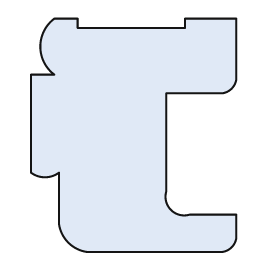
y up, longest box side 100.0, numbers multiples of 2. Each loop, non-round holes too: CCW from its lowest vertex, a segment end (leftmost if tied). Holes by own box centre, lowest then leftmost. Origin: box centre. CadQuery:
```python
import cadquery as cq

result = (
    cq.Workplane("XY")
    .moveTo(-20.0, -50.0)
    .lineTo(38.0, -50.0)
    .threePointArc((42.0, -48.0), (44.0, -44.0))
    .lineTo(44.0, -34.0)
    .lineTo(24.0, -34.0)
    .threePointArc((16.0, -32.0), (14.0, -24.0))
    .lineTo(14.0, 18.0)
    .lineTo(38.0, 18.0)
    .threePointArc((42.0, 20.0), (44.0, 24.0))
    .lineTo(44.0, 50.0)
    .lineTo(22.0, 50.0)
    .lineTo(22.0, 46.0)
    .lineTo(-24.0, 46.0)
    .lineTo(-24.0, 50.0)
    .lineTo(-34.0, 50.0)
    .threePointArc((-40.0, 38.0), (-34.0, 26.0))
    .lineTo(-44.0, 26.0)
    .lineTo(-44.0, -16.0)
    .threePointArc((-38.0, -18.0), (-32.0, -16.0))
    .lineTo(-32.0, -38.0)
    .threePointArc((-28.0, -46.0), (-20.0, -50.0))
    .close()
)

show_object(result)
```